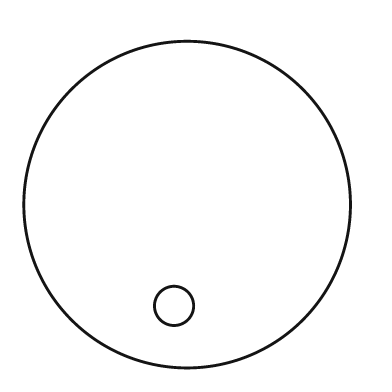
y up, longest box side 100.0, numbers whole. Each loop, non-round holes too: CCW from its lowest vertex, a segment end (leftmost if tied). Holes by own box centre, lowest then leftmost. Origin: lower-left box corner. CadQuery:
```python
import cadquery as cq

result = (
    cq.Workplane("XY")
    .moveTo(50.0, 50.0)
    .circle(50.0)
    .moveTo(46.0, 19.0)
    .circle(6.0)
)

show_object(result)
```